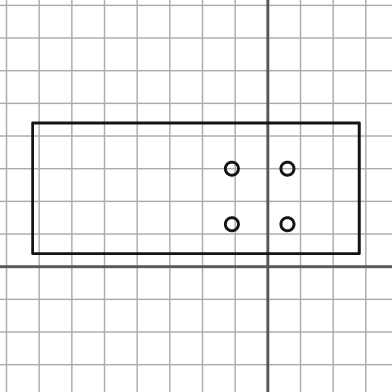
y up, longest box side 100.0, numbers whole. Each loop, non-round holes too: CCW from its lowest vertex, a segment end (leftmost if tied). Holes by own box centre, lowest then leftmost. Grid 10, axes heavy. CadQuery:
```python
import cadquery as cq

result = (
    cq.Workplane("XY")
    .moveTo(-72.0, 4.0)
    .lineTo(28.0, 4.0)
    .lineTo(28.0, 44.0)
    .lineTo(-72.0, 44.0)
    .close()
    .moveTo(-11.0, 13.0)
    .circle(2.0)
    .moveTo(6.0, 13.0)
    .circle(2.0)
    .moveTo(-11.0, 30.0)
    .circle(2.0)
    .moveTo(6.0, 30.0)
    .circle(2.0)
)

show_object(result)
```